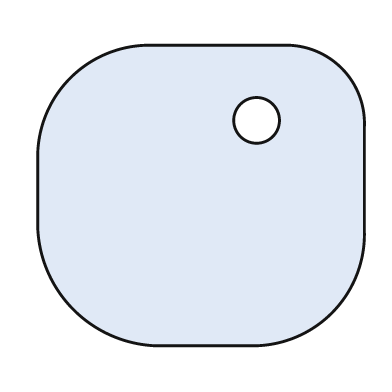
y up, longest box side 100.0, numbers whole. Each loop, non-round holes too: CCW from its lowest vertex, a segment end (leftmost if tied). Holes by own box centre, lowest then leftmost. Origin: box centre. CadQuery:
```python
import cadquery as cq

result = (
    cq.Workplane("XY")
    .moveTo(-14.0, -46.0)
    .lineTo(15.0, -46.0)
    .threePointArc((40.0, -36.0), (50.0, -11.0))
    .lineTo(50.0, 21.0)
    .threePointArc((43.0, 39.0), (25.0, 46.0))
    .lineTo(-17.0, 46.0)
    .threePointArc((-40.0, 36.0), (-50.0, 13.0))
    .lineTo(-50.0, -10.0)
    .threePointArc((-39.0, -35.0), (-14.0, -46.0))
    .close()
    .moveTo(17.0, 23.0)
    .circle(7.0)
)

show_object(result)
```